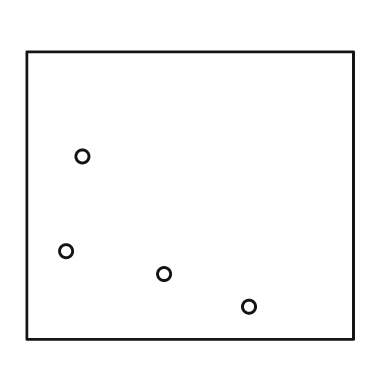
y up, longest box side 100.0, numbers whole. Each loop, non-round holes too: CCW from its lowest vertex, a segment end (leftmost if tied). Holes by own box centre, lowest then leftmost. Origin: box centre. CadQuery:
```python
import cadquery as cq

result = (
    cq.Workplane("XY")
    .moveTo(-50.0, -44.0)
    .lineTo(50.0, -44.0)
    .lineTo(50.0, 44.0)
    .lineTo(-50.0, 44.0)
    .close()
    .moveTo(18.0, -34.0)
    .circle(2.0)
    .moveTo(-8.0, -24.0)
    .circle(2.0)
    .moveTo(-38.0, -17.0)
    .circle(2.0)
    .moveTo(-33.0, 12.0)
    .circle(2.0)
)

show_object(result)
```